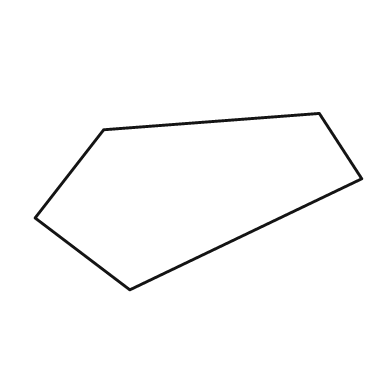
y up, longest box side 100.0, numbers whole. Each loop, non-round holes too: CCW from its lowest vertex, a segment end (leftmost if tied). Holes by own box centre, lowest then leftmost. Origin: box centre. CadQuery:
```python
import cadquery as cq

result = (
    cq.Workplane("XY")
    .moveTo(-21.0, -27.0)
    .lineTo(50.0, 7.0)
    .lineTo(37.0, 27.0)
    .lineTo(-29.0, 22.0)
    .lineTo(-50.0, -5.0)
    .close()
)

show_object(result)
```